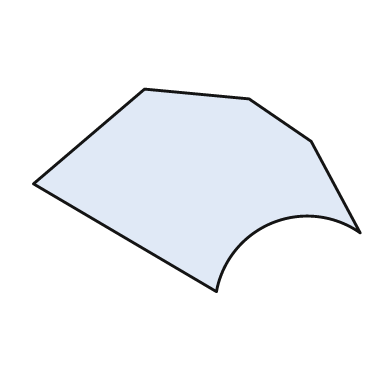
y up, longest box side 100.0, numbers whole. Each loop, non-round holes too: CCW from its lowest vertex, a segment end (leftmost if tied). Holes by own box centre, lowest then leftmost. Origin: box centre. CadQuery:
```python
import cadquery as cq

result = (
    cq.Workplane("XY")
    .moveTo(6.0, -31.0)
    .threePointArc((23.0, -10.0), (50.0, -13.0))
    .lineTo(35.0, 15.0)
    .lineTo(16.0, 28.0)
    .lineTo(-16.0, 31.0)
    .lineTo(-50.0, 2.0)
    .close()
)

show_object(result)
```